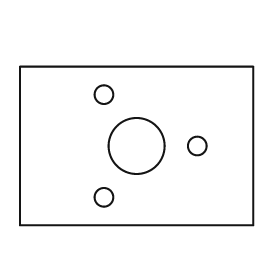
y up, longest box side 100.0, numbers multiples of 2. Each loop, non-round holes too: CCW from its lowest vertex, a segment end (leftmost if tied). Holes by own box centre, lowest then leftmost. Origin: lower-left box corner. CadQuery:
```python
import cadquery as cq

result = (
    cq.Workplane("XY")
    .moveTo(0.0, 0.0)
    .lineTo(100.0, 0.0)
    .lineTo(100.0, 68.0)
    .lineTo(0.0, 68.0)
    .close()
    .moveTo(36.0, 12.0)
    .circle(4.0)
    .moveTo(50.0, 34.0)
    .circle(12.0)
    .moveTo(76.0, 34.0)
    .circle(4.0)
    .moveTo(36.0, 56.0)
    .circle(4.0)
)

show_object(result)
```